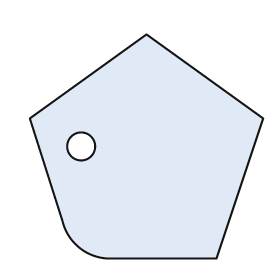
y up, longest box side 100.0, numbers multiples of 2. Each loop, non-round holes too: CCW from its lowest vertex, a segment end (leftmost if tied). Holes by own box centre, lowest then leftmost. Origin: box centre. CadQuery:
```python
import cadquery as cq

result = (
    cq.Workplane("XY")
    .moveTo(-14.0, -48.0)
    .lineTo(30.0, -48.0)
    .lineTo(50.0, 12.0)
    .lineTo(0.0, 48.0)
    .lineTo(-50.0, 12.0)
    .lineTo(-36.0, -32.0)
    .threePointArc((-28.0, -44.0), (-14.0, -48.0))
    .close()
    .moveTo(-28.0, 0.0)
    .circle(6.0)
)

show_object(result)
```